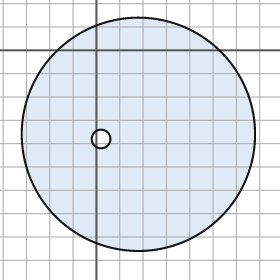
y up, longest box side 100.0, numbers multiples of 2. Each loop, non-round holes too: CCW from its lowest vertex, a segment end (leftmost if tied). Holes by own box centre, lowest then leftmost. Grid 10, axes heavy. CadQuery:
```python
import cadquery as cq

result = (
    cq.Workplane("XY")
    .moveTo(18.0, -36.0)
    .circle(50.0)
    .moveTo(2.0, -38.0)
    .circle(4.0)
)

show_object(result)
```